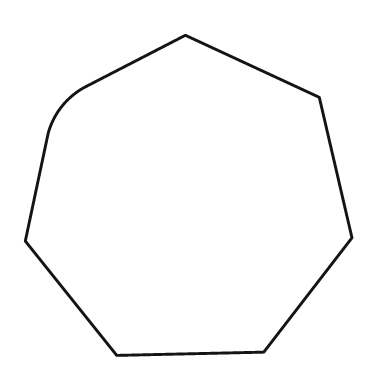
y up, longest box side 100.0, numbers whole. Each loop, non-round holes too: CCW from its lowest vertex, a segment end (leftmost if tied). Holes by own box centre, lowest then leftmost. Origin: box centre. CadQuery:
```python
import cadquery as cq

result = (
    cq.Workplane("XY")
    .moveTo(-22.0, -49.0)
    .lineTo(23.0, -48.0)
    .lineTo(50.0, -13.0)
    .lineTo(40.0, 30.0)
    .lineTo(-1.0, 49.0)
    .lineTo(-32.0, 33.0)
    .threePointArc((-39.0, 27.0), (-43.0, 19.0))
    .lineTo(-50.0, -14.0)
    .close()
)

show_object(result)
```